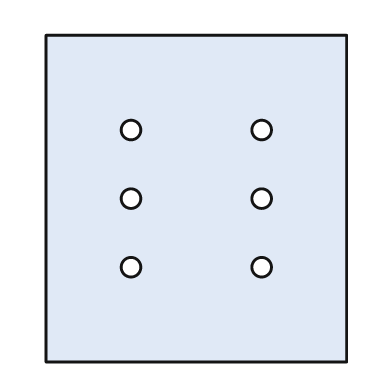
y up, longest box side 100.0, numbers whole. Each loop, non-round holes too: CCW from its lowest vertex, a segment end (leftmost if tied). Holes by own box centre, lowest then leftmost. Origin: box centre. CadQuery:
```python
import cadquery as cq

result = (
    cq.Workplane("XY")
    .moveTo(-46.0, -50.0)
    .lineTo(46.0, -50.0)
    .lineTo(46.0, 50.0)
    .lineTo(-46.0, 50.0)
    .close()
    .moveTo(-20.0, -21.0)
    .circle(3.0)
    .moveTo(20.0, -21.0)
    .circle(3.0)
    .moveTo(-20.0, 0.0)
    .circle(3.0)
    .moveTo(20.0, 0.0)
    .circle(3.0)
    .moveTo(-20.0, 21.0)
    .circle(3.0)
    .moveTo(20.0, 21.0)
    .circle(3.0)
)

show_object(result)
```